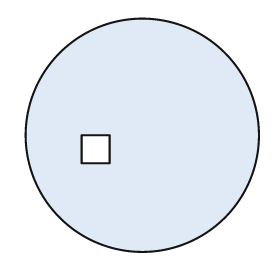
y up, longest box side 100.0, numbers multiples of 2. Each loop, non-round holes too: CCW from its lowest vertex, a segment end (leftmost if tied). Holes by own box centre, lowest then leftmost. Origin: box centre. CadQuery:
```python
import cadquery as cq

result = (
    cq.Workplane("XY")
    .moveTo(0.0, 0.0)
    .circle(50.0)
    .moveTo(-26.0, -12.0)
    .lineTo(-14.0, -12.0)
    .lineTo(-14.0, 0.0)
    .lineTo(-26.0, 0.0)
    .close()
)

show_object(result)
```